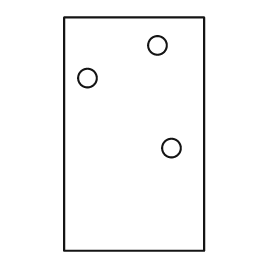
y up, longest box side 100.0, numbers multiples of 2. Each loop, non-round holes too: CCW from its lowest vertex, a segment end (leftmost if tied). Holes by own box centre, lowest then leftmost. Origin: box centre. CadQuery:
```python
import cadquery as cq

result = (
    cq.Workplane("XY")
    .moveTo(-30.0, -50.0)
    .lineTo(30.0, -50.0)
    .lineTo(30.0, 50.0)
    .lineTo(-30.0, 50.0)
    .close()
    .moveTo(16.0, -6.0)
    .circle(4.0)
    .moveTo(-20.0, 24.0)
    .circle(4.0)
    .moveTo(10.0, 38.0)
    .circle(4.0)
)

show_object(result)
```